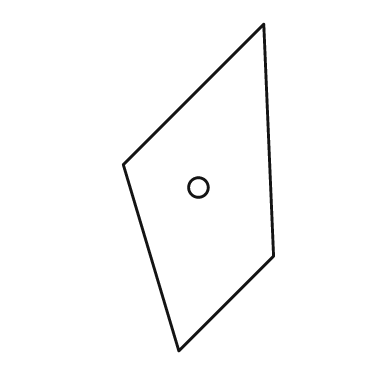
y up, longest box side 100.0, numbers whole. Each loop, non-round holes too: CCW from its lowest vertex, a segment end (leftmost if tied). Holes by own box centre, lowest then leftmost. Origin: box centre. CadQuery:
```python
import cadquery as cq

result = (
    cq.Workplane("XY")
    .moveTo(-6.0, -50.0)
    .lineTo(23.0, -21.0)
    .lineTo(20.0, 50.0)
    .lineTo(-23.0, 7.0)
    .close()
    .moveTo(0.0, 0.0)
    .circle(3.0)
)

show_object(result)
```